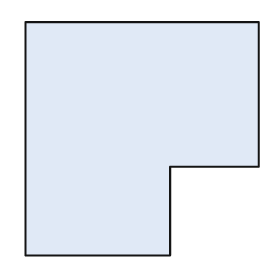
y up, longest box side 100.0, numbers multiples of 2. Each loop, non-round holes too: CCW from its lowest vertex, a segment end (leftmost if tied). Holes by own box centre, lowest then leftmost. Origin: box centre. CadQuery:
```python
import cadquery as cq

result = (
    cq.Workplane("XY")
    .moveTo(-50.0, -50.0)
    .lineTo(12.0, -50.0)
    .lineTo(12.0, -12.0)
    .lineTo(50.0, -12.0)
    .lineTo(50.0, 50.0)
    .lineTo(-50.0, 50.0)
    .close()
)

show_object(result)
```